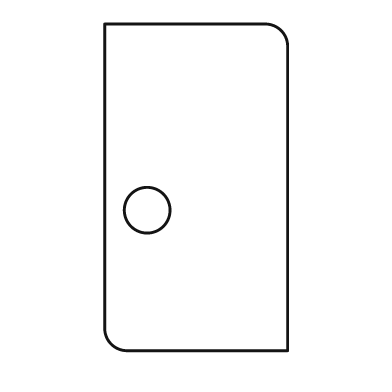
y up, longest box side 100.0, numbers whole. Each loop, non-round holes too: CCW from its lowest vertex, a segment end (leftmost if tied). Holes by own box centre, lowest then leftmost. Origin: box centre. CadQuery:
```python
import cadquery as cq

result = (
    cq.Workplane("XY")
    .moveTo(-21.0, -50.0)
    .lineTo(28.0, -50.0)
    .lineTo(28.0, 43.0)
    .threePointArc((26.0, 48.0), (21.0, 50.0))
    .lineTo(-28.0, 50.0)
    .lineTo(-28.0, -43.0)
    .threePointArc((-26.0, -48.0), (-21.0, -50.0))
    .close()
    .moveTo(-15.0, -7.0)
    .circle(7.0)
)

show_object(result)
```